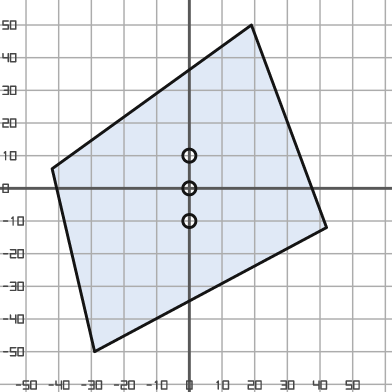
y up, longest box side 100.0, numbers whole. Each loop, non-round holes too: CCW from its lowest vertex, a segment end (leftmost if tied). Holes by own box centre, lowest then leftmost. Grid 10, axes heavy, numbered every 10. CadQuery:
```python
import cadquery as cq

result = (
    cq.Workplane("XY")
    .moveTo(-29.0, -50.0)
    .lineTo(42.0, -12.0)
    .lineTo(19.0, 50.0)
    .lineTo(-42.0, 6.0)
    .close()
    .moveTo(0.0, -10.0)
    .circle(2.0)
    .moveTo(0.0, 0.0)
    .circle(2.0)
    .moveTo(0.0, 10.0)
    .circle(2.0)
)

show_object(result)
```